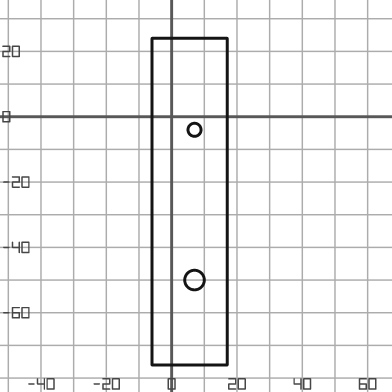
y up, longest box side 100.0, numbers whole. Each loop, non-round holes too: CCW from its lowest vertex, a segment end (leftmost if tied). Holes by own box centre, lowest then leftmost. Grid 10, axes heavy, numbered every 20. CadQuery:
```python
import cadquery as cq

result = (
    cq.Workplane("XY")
    .moveTo(-6.0, -76.0)
    .lineTo(17.0, -76.0)
    .lineTo(17.0, 24.0)
    .lineTo(-6.0, 24.0)
    .close()
    .moveTo(7.0, -50.0)
    .circle(3.0)
    .moveTo(7.0, -4.0)
    .circle(2.0)
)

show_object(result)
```